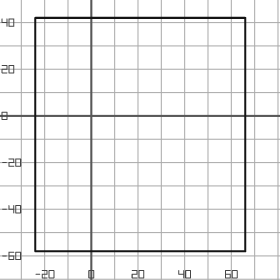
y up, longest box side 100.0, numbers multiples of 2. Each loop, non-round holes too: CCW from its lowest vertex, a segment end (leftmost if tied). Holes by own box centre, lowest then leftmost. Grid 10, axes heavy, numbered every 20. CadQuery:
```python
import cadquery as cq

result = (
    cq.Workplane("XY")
    .moveTo(-24.0, -58.0)
    .lineTo(66.0, -58.0)
    .lineTo(66.0, 42.0)
    .lineTo(-24.0, 42.0)
    .close()
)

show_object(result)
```